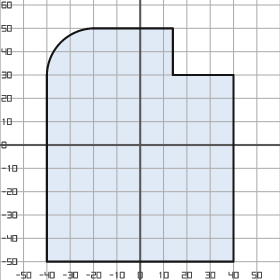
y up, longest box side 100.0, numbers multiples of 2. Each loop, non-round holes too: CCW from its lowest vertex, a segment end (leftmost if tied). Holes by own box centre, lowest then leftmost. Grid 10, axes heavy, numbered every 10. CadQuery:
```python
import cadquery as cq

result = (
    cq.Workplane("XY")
    .moveTo(-40.0, -50.0)
    .lineTo(40.0, -50.0)
    .lineTo(40.0, 30.0)
    .lineTo(14.0, 30.0)
    .lineTo(14.0, 50.0)
    .lineTo(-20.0, 50.0)
    .threePointArc((-34.0, 44.0), (-40.0, 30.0))
    .close()
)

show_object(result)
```